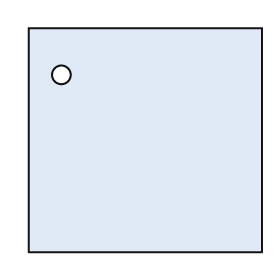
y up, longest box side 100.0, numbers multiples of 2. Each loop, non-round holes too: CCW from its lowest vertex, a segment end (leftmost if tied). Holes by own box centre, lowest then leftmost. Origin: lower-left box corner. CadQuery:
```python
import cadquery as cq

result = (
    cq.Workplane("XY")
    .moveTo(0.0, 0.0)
    .lineTo(100.0, 0.0)
    .lineTo(100.0, 96.0)
    .lineTo(0.0, 96.0)
    .close()
    .moveTo(14.0, 76.0)
    .circle(4.0)
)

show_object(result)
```